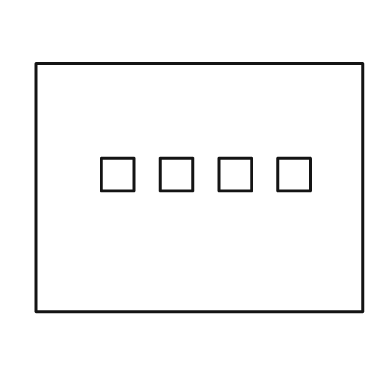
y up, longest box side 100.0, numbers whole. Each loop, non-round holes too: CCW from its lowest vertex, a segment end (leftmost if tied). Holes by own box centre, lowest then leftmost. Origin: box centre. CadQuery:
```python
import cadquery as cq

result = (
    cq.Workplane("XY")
    .moveTo(-50.0, -38.0)
    .lineTo(50.0, -38.0)
    .lineTo(50.0, 38.0)
    .lineTo(-50.0, 38.0)
    .close()
    .moveTo(-30.0, -1.0)
    .lineTo(-20.0, -1.0)
    .lineTo(-20.0, 9.0)
    .lineTo(-30.0, 9.0)
    .close()
    .moveTo(-12.0, -1.0)
    .lineTo(-2.0, -1.0)
    .lineTo(-2.0, 9.0)
    .lineTo(-12.0, 9.0)
    .close()
    .moveTo(6.0, -1.0)
    .lineTo(16.0, -1.0)
    .lineTo(16.0, 9.0)
    .lineTo(6.0, 9.0)
    .close()
    .moveTo(24.0, -1.0)
    .lineTo(34.0, -1.0)
    .lineTo(34.0, 9.0)
    .lineTo(24.0, 9.0)
    .close()
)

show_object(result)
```